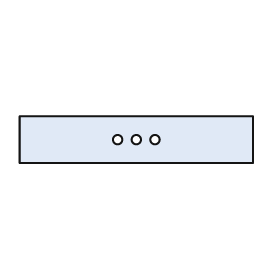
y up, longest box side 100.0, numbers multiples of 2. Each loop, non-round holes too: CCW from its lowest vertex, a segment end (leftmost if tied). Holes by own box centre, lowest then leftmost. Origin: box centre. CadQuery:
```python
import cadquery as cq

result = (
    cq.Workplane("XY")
    .moveTo(-50.0, -10.0)
    .lineTo(50.0, -10.0)
    .lineTo(50.0, 10.0)
    .lineTo(-50.0, 10.0)
    .close()
    .moveTo(-8.0, 0.0)
    .circle(2.0)
    .moveTo(0.0, 0.0)
    .circle(2.0)
    .moveTo(8.0, 0.0)
    .circle(2.0)
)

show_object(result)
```